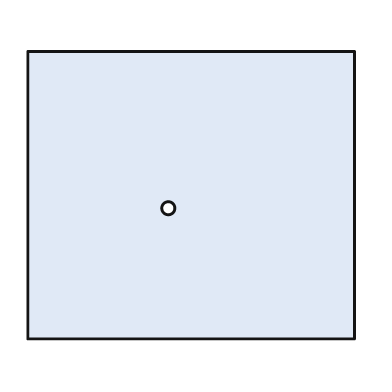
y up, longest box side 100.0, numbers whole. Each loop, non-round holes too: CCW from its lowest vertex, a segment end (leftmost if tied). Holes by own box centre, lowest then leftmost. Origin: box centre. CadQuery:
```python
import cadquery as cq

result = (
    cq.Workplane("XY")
    .moveTo(-50.0, -44.0)
    .lineTo(50.0, -44.0)
    .lineTo(50.0, 44.0)
    .lineTo(-50.0, 44.0)
    .close()
    .moveTo(-7.0, -4.0)
    .circle(2.0)
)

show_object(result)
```